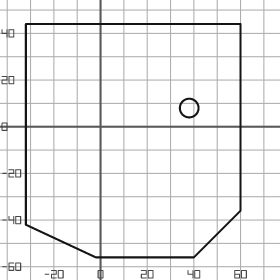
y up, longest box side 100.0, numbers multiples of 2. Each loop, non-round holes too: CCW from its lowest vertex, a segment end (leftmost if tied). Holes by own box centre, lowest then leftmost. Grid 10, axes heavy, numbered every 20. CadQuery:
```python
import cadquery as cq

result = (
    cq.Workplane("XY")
    .moveTo(-2.0, -56.0)
    .lineTo(40.0, -56.0)
    .lineTo(60.0, -36.0)
    .lineTo(60.0, 44.0)
    .lineTo(-32.0, 44.0)
    .lineTo(-32.0, -42.0)
    .close()
    .moveTo(38.0, 8.0)
    .circle(4.0)
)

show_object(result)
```